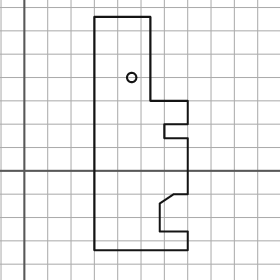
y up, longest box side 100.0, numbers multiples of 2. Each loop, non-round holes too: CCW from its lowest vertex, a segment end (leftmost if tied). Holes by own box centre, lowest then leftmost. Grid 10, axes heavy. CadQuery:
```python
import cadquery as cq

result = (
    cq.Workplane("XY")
    .moveTo(30.0, -34.0)
    .lineTo(70.0, -34.0)
    .lineTo(70.0, -26.0)
    .lineTo(58.0, -26.0)
    .lineTo(58.0, -14.0)
    .lineTo(64.0, -10.0)
    .lineTo(70.0, -10.0)
    .lineTo(70.0, 14.0)
    .lineTo(60.0, 14.0)
    .lineTo(60.0, 20.0)
    .lineTo(70.0, 20.0)
    .lineTo(70.0, 30.0)
    .lineTo(54.0, 30.0)
    .lineTo(54.0, 66.0)
    .lineTo(30.0, 66.0)
    .close()
    .moveTo(46.0, 40.0)
    .circle(2.0)
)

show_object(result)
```